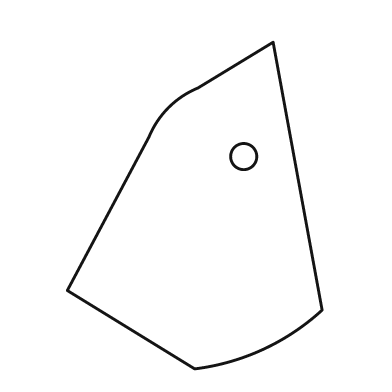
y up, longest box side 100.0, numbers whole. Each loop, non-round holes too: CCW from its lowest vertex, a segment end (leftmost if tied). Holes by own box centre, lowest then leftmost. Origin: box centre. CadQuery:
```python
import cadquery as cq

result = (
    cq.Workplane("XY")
    .moveTo(0.0, -50.0)
    .threePointArc((21.0, -44.0), (39.0, -32.0))
    .lineTo(24.0, 50.0)
    .lineTo(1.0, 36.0)
    .threePointArc((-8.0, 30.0), (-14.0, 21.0))
    .lineTo(-39.0, -26.0)
    .close()
    .moveTo(15.0, 15.0)
    .circle(4.0)
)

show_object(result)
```